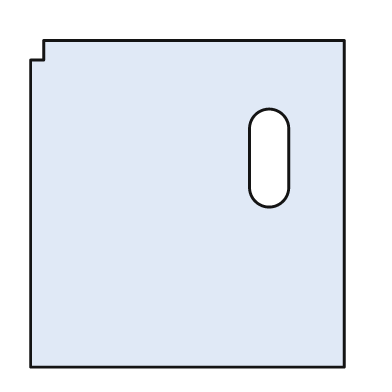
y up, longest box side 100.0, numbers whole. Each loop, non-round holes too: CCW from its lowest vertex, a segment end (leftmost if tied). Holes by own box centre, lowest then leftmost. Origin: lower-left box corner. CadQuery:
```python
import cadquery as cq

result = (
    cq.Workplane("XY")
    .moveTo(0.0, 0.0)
    .lineTo(96.0, 0.0)
    .lineTo(96.0, 100.0)
    .lineTo(4.0, 100.0)
    .lineTo(4.0, 94.0)
    .lineTo(0.0, 94.0)
    .close()
    .moveTo(67.0, 55.0)
    .threePointArc((73.0, 49.0), (79.0, 55.0))
    .lineTo(79.0, 73.0)
    .threePointArc((73.0, 79.0), (67.0, 73.0))
    .close()
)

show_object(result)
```